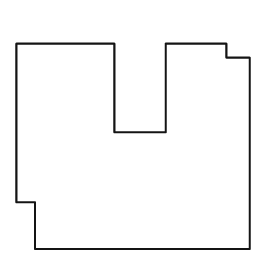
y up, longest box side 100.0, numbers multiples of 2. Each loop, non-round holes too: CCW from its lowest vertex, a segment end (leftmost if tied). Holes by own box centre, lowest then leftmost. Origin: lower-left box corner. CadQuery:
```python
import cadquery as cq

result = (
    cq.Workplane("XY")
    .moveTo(8.0, 0.0)
    .lineTo(100.0, 0.0)
    .lineTo(100.0, 82.0)
    .lineTo(90.0, 82.0)
    .lineTo(90.0, 88.0)
    .lineTo(64.0, 88.0)
    .lineTo(64.0, 50.0)
    .lineTo(42.0, 50.0)
    .lineTo(42.0, 88.0)
    .lineTo(0.0, 88.0)
    .lineTo(0.0, 20.0)
    .lineTo(8.0, 20.0)
    .close()
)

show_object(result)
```